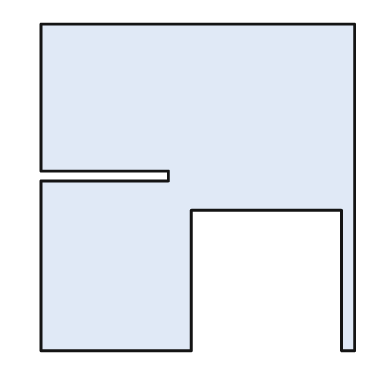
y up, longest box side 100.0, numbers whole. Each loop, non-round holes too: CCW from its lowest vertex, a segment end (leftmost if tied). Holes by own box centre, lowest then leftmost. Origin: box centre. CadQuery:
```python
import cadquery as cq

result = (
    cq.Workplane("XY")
    .moveTo(-48.0, -50.0)
    .lineTo(-2.0, -50.0)
    .lineTo(-2.0, -7.0)
    .lineTo(44.0, -7.0)
    .lineTo(44.0, -50.0)
    .lineTo(48.0, -50.0)
    .lineTo(48.0, 50.0)
    .lineTo(-48.0, 50.0)
    .lineTo(-48.0, 5.0)
    .lineTo(-9.0, 5.0)
    .lineTo(-9.0, 2.0)
    .lineTo(-48.0, 2.0)
    .close()
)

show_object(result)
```